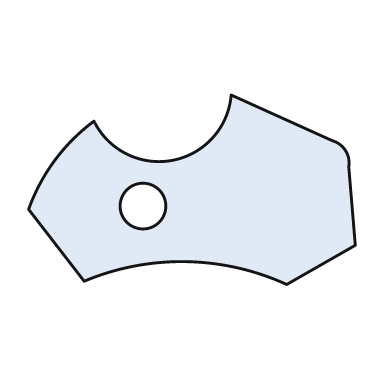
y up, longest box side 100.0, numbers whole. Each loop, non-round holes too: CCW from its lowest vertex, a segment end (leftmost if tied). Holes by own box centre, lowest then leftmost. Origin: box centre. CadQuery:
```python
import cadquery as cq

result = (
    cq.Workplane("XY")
    .moveTo(29.0, -29.0)
    .lineTo(50.0, -17.0)
    .lineTo(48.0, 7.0)
    .threePointArc((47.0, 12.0), (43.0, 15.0))
    .lineTo(12.0, 29.0)
    .threePointArc((-6.0, 9.0), (-30.0, 21.0))
    .threePointArc((-42.0, 9.0), (-50.0, -6.0))
    .lineTo(-33.0, -28.0)
    .threePointArc((-2.0, -22.0), (29.0, -29.0))
    .close()
    .moveTo(-15.0, -5.0)
    .circle(7.0)
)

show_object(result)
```